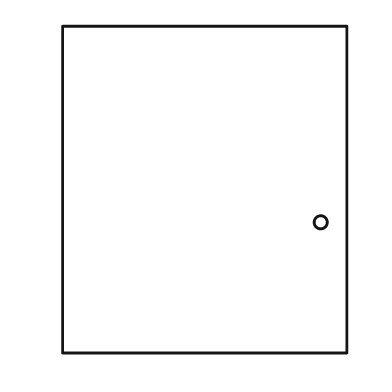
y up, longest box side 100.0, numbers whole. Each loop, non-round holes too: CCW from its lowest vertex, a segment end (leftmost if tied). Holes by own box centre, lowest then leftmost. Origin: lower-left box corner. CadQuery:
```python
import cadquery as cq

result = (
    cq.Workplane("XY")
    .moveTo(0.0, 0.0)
    .lineTo(87.0, 0.0)
    .lineTo(87.0, 100.0)
    .lineTo(0.0, 100.0)
    .close()
    .moveTo(79.0, 40.0)
    .circle(2.0)
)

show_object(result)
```